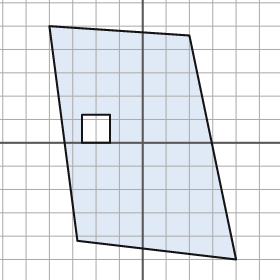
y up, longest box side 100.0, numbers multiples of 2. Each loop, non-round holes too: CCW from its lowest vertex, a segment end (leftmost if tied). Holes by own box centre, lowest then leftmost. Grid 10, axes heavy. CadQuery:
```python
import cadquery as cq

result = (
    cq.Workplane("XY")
    .moveTo(40.0, -50.0)
    .lineTo(20.0, 46.0)
    .lineTo(-40.0, 50.0)
    .lineTo(-28.0, -42.0)
    .close()
    .moveTo(-26.0, 0.0)
    .lineTo(-14.0, 0.0)
    .lineTo(-14.0, 12.0)
    .lineTo(-26.0, 12.0)
    .close()
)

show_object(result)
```